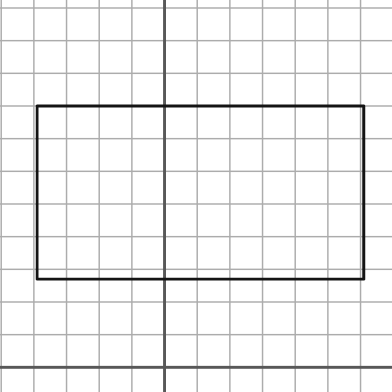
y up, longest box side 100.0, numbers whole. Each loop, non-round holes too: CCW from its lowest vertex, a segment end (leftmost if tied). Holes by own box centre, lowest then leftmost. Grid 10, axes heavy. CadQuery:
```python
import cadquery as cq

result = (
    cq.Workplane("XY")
    .moveTo(-39.0, 27.0)
    .lineTo(61.0, 27.0)
    .lineTo(61.0, 80.0)
    .lineTo(-39.0, 80.0)
    .close()
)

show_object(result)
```